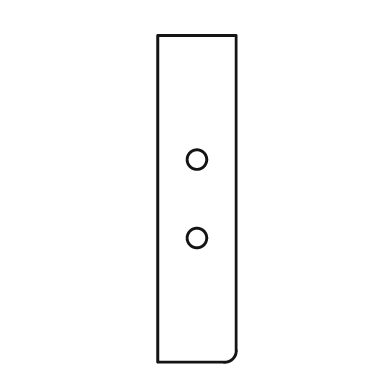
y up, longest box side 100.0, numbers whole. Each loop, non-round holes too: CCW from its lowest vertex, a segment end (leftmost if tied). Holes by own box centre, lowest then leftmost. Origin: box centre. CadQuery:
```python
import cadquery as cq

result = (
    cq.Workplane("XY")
    .moveTo(-12.0, -50.0)
    .lineTo(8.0, -50.0)
    .threePointArc((11.0, -49.0), (12.0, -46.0))
    .lineTo(12.0, 50.0)
    .lineTo(-12.0, 50.0)
    .close()
    .moveTo(0.0, -12.0)
    .circle(3.0)
    .moveTo(0.0, 12.0)
    .circle(3.0)
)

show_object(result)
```